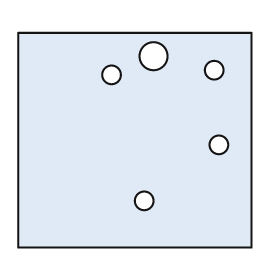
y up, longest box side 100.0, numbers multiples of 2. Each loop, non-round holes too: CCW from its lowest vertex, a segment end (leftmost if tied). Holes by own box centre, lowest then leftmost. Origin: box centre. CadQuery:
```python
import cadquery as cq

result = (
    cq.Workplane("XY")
    .moveTo(-50.0, -46.0)
    .lineTo(50.0, -46.0)
    .lineTo(50.0, 46.0)
    .lineTo(-50.0, 46.0)
    .close()
    .moveTo(4.0, -26.0)
    .circle(4.0)
    .moveTo(36.0, -2.0)
    .circle(4.0)
    .moveTo(-10.0, 28.0)
    .circle(4.0)
    .moveTo(34.0, 30.0)
    .circle(4.0)
    .moveTo(8.0, 36.0)
    .circle(6.0)
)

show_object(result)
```